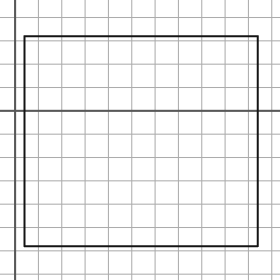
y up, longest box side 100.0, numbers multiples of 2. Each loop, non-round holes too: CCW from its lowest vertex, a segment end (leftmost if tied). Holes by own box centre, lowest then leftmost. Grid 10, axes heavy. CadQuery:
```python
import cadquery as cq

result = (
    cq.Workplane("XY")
    .moveTo(4.0, -58.0)
    .lineTo(104.0, -58.0)
    .lineTo(104.0, 32.0)
    .lineTo(4.0, 32.0)
    .close()
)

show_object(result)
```